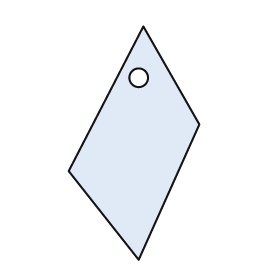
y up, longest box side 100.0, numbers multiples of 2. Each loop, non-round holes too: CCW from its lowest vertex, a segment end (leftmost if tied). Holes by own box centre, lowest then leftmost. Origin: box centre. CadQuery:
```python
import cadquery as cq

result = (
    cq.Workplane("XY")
    .moveTo(2.0, -50.0)
    .lineTo(28.0, 8.0)
    .lineTo(4.0, 50.0)
    .lineTo(-28.0, -12.0)
    .close()
    .moveTo(2.0, 28.0)
    .circle(4.0)
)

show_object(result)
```